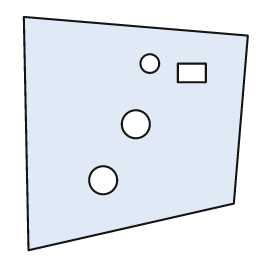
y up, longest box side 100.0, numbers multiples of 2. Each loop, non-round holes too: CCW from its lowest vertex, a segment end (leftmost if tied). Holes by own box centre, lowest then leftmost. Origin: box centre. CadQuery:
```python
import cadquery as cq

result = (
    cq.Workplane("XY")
    .moveTo(-46.0, -50.0)
    .lineTo(42.0, -30.0)
    .lineTo(48.0, 42.0)
    .lineTo(-48.0, 50.0)
    .close()
    .moveTo(-14.0, -20.0)
    .circle(6.0)
    .moveTo(0.0, 4.0)
    .circle(6.0)
    .moveTo(18.0, 22.0)
    .lineTo(30.0, 22.0)
    .lineTo(30.0, 30.0)
    .lineTo(18.0, 30.0)
    .close()
    .moveTo(6.0, 30.0)
    .circle(4.0)
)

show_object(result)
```